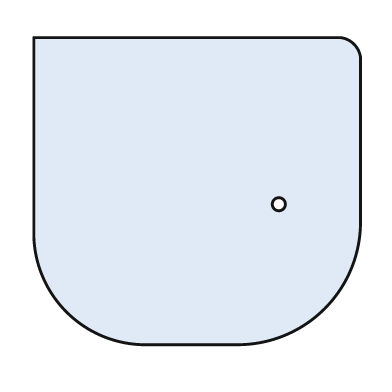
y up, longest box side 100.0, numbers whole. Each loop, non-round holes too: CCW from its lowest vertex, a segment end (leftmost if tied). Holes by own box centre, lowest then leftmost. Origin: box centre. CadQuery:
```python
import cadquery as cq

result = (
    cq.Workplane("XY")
    .moveTo(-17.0, -47.0)
    .lineTo(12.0, -47.0)
    .threePointArc((39.0, -36.0), (50.0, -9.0))
    .lineTo(50.0, 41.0)
    .threePointArc((48.0, 45.0), (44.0, 47.0))
    .lineTo(-50.0, 47.0)
    .lineTo(-50.0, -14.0)
    .threePointArc((-40.0, -37.0), (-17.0, -47.0))
    .close()
    .moveTo(25.0, -4.0)
    .circle(2.0)
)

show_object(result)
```